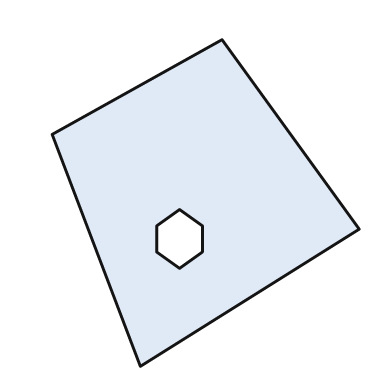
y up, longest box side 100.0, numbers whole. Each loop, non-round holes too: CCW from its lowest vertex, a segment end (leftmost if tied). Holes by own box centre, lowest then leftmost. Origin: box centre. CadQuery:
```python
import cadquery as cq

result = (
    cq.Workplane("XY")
    .moveTo(-20.0, -50.0)
    .lineTo(47.0, -8.0)
    .lineTo(5.0, 50.0)
    .lineTo(-47.0, 21.0)
    .close()
    .moveTo(-8.0, -20.0)
    .lineTo(-1.0, -15.0)
    .lineTo(-1.0, -7.0)
    .lineTo(-8.0, -2.0)
    .lineTo(-15.0, -7.0)
    .lineTo(-15.0, -15.0)
    .close()
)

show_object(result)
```